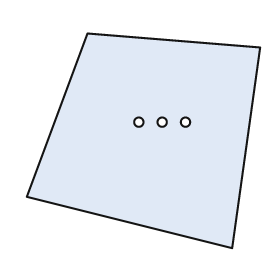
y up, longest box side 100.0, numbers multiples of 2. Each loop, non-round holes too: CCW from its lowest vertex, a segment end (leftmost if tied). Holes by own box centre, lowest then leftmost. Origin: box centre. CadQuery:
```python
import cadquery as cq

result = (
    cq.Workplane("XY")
    .moveTo(38.0, -46.0)
    .lineTo(50.0, 40.0)
    .lineTo(-24.0, 46.0)
    .lineTo(-50.0, -24.0)
    .close()
    .moveTo(-2.0, 8.0)
    .circle(2.0)
    .moveTo(8.0, 8.0)
    .circle(2.0)
    .moveTo(18.0, 8.0)
    .circle(2.0)
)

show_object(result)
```